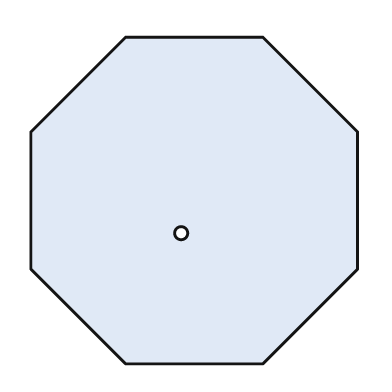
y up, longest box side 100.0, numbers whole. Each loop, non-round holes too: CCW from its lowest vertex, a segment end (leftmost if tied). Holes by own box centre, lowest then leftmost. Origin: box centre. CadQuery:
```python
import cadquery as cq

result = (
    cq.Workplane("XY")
    .moveTo(-21.0, -50.0)
    .lineTo(21.0, -50.0)
    .lineTo(50.0, -21.0)
    .lineTo(50.0, 21.0)
    .lineTo(21.0, 50.0)
    .lineTo(-21.0, 50.0)
    .lineTo(-50.0, 21.0)
    .lineTo(-50.0, -21.0)
    .close()
    .moveTo(-4.0, -10.0)
    .circle(2.0)
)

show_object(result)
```